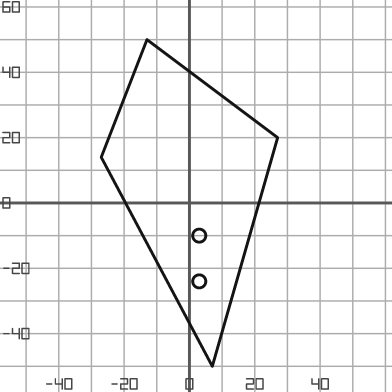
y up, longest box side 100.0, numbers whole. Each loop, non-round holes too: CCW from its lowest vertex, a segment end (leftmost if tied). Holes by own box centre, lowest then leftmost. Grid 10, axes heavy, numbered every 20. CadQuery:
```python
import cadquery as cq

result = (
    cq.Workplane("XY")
    .moveTo(7.0, -50.0)
    .lineTo(27.0, 20.0)
    .lineTo(-13.0, 50.0)
    .lineTo(-27.0, 14.0)
    .close()
    .moveTo(3.0, -24.0)
    .circle(2.0)
    .moveTo(3.0, -10.0)
    .circle(2.0)
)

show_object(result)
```